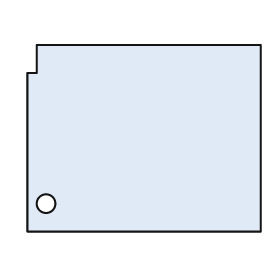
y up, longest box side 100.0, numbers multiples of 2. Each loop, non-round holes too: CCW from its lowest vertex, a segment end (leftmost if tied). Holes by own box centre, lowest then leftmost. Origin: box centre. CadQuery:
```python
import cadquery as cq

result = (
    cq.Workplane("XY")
    .moveTo(-50.0, -40.0)
    .lineTo(50.0, -40.0)
    .lineTo(50.0, 40.0)
    .lineTo(-46.0, 40.0)
    .lineTo(-46.0, 28.0)
    .lineTo(-50.0, 28.0)
    .close()
    .moveTo(-42.0, -28.0)
    .circle(4.0)
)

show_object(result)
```